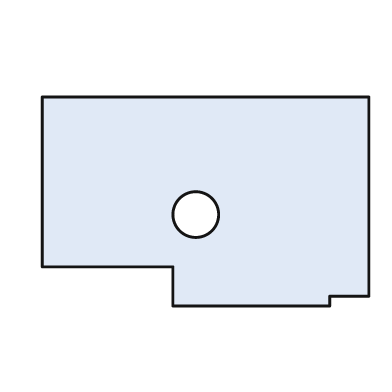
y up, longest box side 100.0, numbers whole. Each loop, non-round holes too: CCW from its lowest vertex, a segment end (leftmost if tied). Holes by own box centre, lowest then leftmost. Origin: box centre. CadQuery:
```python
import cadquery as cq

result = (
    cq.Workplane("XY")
    .moveTo(-10.0, -32.0)
    .lineTo(38.0, -32.0)
    .lineTo(38.0, -29.0)
    .lineTo(50.0, -29.0)
    .lineTo(50.0, 32.0)
    .lineTo(-50.0, 32.0)
    .lineTo(-50.0, -20.0)
    .lineTo(-10.0, -20.0)
    .close()
    .moveTo(-3.0, -4.0)
    .circle(7.0)
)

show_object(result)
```